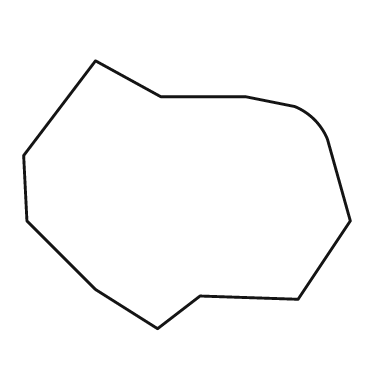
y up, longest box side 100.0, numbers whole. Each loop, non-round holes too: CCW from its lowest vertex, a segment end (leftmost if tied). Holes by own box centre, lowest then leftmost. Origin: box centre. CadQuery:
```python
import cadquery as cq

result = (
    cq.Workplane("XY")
    .moveTo(-9.0, -41.0)
    .lineTo(4.0, -31.0)
    .lineTo(34.0, -32.0)
    .lineTo(50.0, -8.0)
    .lineTo(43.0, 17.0)
    .threePointArc((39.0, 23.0), (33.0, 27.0))
    .lineTo(18.0, 30.0)
    .lineTo(-8.0, 30.0)
    .lineTo(-28.0, 41.0)
    .lineTo(-50.0, 12.0)
    .lineTo(-49.0, -8.0)
    .lineTo(-28.0, -29.0)
    .close()
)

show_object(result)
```